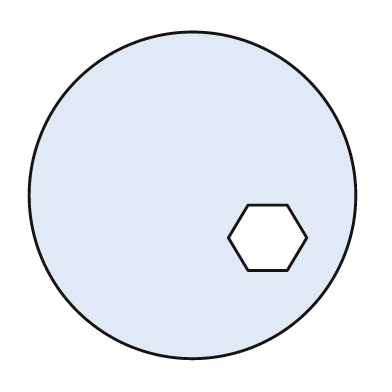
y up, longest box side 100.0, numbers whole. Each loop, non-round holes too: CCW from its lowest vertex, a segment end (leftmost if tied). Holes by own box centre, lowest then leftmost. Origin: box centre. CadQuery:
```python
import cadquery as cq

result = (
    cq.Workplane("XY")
    .moveTo(0.0, 0.0)
    .circle(50.0)
    .moveTo(17.0, -23.0)
    .lineTo(29.0, -23.0)
    .lineTo(35.0, -13.0)
    .lineTo(29.0, -3.0)
    .lineTo(17.0, -3.0)
    .lineTo(11.0, -13.0)
    .close()
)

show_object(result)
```